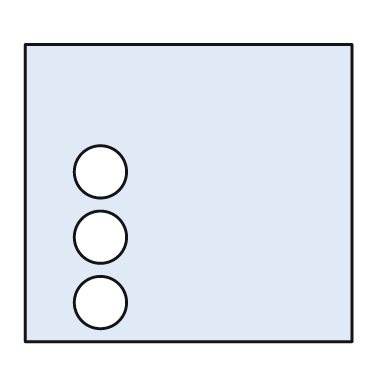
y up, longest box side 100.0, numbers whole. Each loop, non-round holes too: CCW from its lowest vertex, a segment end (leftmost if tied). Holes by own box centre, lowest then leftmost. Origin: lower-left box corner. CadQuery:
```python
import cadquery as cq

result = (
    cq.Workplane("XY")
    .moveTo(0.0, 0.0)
    .lineTo(100.0, 0.0)
    .lineTo(100.0, 91.0)
    .lineTo(0.0, 91.0)
    .close()
    .moveTo(23.0, 12.0)
    .circle(8.0)
    .moveTo(23.0, 32.0)
    .circle(8.0)
    .moveTo(23.0, 52.0)
    .circle(8.0)
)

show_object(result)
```